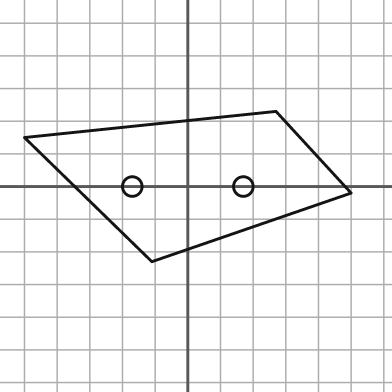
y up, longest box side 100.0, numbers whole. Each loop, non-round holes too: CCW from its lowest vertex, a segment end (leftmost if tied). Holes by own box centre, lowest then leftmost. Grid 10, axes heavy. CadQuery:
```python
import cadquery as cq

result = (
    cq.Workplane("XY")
    .moveTo(-11.0, -23.0)
    .lineTo(50.0, -2.0)
    .lineTo(27.0, 23.0)
    .lineTo(-50.0, 15.0)
    .close()
    .moveTo(-17.0, 0.0)
    .circle(3.0)
    .moveTo(17.0, 0.0)
    .circle(3.0)
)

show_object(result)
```